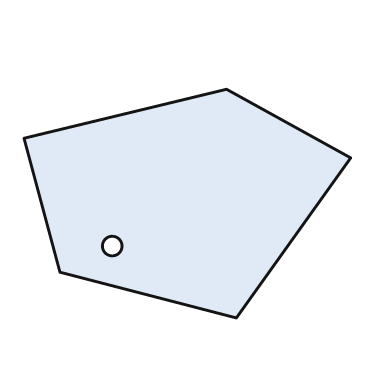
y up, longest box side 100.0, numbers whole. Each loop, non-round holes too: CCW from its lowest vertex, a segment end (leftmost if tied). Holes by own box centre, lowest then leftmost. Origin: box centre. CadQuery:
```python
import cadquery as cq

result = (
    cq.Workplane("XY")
    .moveTo(15.0, -35.0)
    .lineTo(50.0, 14.0)
    .lineTo(12.0, 35.0)
    .lineTo(-50.0, 20.0)
    .lineTo(-39.0, -21.0)
    .close()
    .moveTo(-23.0, -13.0)
    .circle(3.0)
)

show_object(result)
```